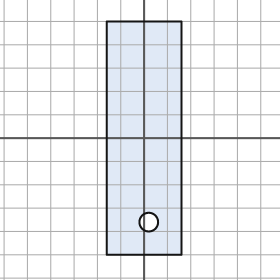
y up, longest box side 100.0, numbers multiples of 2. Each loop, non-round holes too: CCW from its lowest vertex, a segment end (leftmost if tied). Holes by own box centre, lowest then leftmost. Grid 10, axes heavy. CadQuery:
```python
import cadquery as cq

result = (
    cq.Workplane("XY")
    .moveTo(-16.0, -50.0)
    .lineTo(16.0, -50.0)
    .lineTo(16.0, 50.0)
    .lineTo(-16.0, 50.0)
    .close()
    .moveTo(2.0, -36.0)
    .circle(4.0)
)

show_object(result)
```